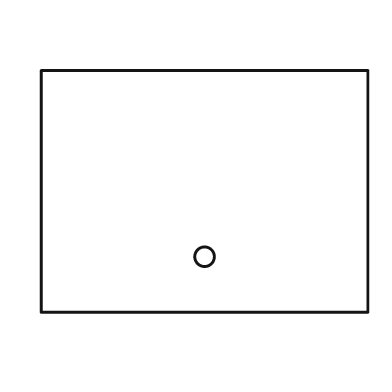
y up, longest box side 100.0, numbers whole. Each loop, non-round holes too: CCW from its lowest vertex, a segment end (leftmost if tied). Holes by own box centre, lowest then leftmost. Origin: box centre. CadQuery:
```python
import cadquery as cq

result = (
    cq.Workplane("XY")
    .moveTo(-50.0, -37.0)
    .lineTo(50.0, -37.0)
    .lineTo(50.0, 37.0)
    .lineTo(-50.0, 37.0)
    .close()
    .moveTo(0.0, -20.0)
    .circle(3.0)
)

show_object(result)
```